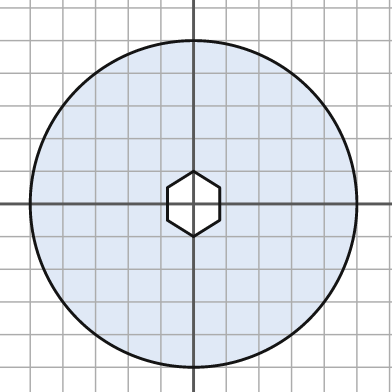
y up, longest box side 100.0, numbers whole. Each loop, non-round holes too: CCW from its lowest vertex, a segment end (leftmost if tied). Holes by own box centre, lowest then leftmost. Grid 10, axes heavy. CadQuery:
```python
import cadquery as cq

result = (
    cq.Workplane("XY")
    .moveTo(0.0, 0.0)
    .circle(50.0)
    .moveTo(0.0, -10.0)
    .lineTo(8.0, -5.0)
    .lineTo(8.0, 5.0)
    .lineTo(0.0, 10.0)
    .lineTo(-8.0, 5.0)
    .lineTo(-8.0, -5.0)
    .close()
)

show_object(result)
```